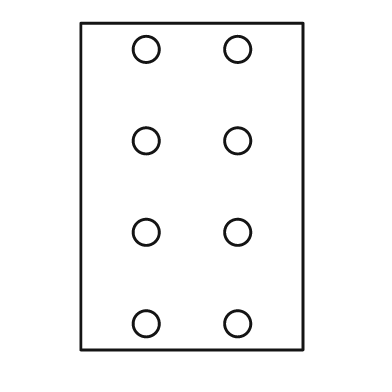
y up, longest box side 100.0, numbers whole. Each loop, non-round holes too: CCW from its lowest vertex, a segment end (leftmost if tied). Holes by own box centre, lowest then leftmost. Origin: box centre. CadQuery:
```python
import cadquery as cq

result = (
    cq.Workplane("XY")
    .moveTo(-34.0, -50.0)
    .lineTo(34.0, -50.0)
    .lineTo(34.0, 50.0)
    .lineTo(-34.0, 50.0)
    .close()
    .moveTo(-14.0, -42.0)
    .circle(4.0)
    .moveTo(14.0, -42.0)
    .circle(4.0)
    .moveTo(-14.0, -14.0)
    .circle(4.0)
    .moveTo(14.0, -14.0)
    .circle(4.0)
    .moveTo(-14.0, 14.0)
    .circle(4.0)
    .moveTo(14.0, 14.0)
    .circle(4.0)
    .moveTo(-14.0, 42.0)
    .circle(4.0)
    .moveTo(14.0, 42.0)
    .circle(4.0)
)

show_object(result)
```